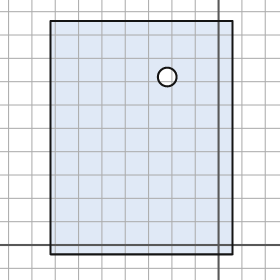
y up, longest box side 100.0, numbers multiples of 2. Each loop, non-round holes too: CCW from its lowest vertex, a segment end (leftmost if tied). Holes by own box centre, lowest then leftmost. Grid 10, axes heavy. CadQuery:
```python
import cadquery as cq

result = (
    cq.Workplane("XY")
    .moveTo(-72.0, -4.0)
    .lineTo(6.0, -4.0)
    .lineTo(6.0, 96.0)
    .lineTo(-72.0, 96.0)
    .close()
    .moveTo(-22.0, 72.0)
    .circle(4.0)
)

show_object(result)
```